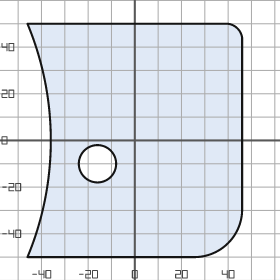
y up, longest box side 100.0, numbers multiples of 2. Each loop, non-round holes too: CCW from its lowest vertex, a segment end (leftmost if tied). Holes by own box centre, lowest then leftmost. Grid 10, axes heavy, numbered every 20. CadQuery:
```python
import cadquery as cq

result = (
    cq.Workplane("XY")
    .moveTo(-46.0, -50.0)
    .lineTo(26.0, -50.0)
    .threePointArc((40.0, -44.0), (46.0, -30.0))
    .lineTo(46.0, 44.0)
    .threePointArc((44.0, 48.0), (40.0, 50.0))
    .lineTo(-46.0, 50.0)
    .threePointArc((-36.0, 0.0), (-46.0, -50.0))
    .close()
    .moveTo(-16.0, -10.0)
    .circle(8.0)
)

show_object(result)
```